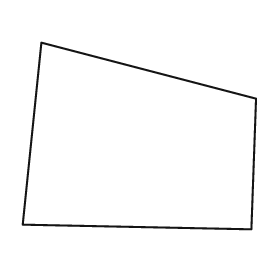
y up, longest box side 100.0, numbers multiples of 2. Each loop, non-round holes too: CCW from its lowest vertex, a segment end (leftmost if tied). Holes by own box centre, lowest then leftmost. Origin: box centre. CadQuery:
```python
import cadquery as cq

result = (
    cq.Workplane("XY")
    .moveTo(48.0, -40.0)
    .lineTo(50.0, 16.0)
    .lineTo(-42.0, 40.0)
    .lineTo(-50.0, -38.0)
    .close()
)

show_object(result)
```